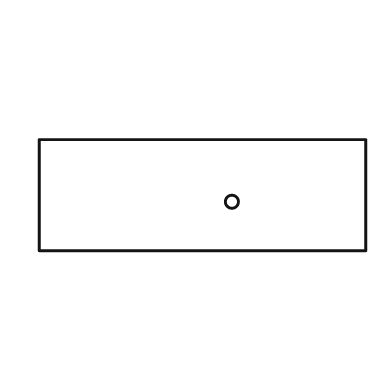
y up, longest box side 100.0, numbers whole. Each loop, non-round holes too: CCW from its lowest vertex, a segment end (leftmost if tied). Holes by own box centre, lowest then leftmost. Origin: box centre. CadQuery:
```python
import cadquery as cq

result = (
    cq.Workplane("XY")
    .moveTo(-50.0, -17.0)
    .lineTo(50.0, -17.0)
    .lineTo(50.0, 17.0)
    .lineTo(-50.0, 17.0)
    .close()
    .moveTo(9.0, -2.0)
    .circle(2.0)
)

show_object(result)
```